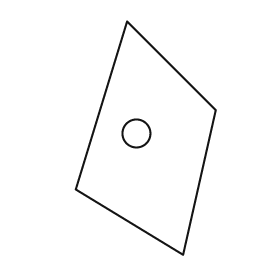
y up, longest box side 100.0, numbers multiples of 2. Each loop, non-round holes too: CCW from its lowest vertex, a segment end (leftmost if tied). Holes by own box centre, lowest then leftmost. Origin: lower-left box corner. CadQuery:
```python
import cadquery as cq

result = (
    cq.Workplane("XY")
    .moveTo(46.0, 0.0)
    .lineTo(60.0, 62.0)
    .lineTo(22.0, 100.0)
    .lineTo(0.0, 28.0)
    .close()
    .moveTo(26.0, 52.0)
    .circle(6.0)
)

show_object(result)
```